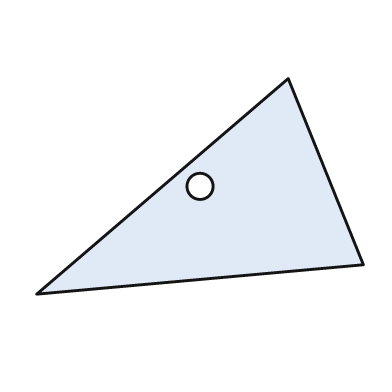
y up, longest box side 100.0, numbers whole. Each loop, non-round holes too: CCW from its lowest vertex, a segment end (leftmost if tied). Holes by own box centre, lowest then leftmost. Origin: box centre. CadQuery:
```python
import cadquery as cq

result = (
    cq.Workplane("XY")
    .moveTo(-50.0, -33.0)
    .lineTo(50.0, -24.0)
    .lineTo(27.0, 33.0)
    .close()
    .moveTo(0.0, 0.0)
    .circle(4.0)
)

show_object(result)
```